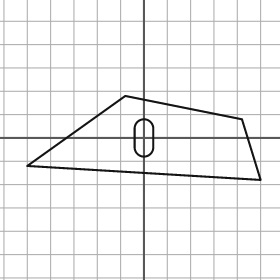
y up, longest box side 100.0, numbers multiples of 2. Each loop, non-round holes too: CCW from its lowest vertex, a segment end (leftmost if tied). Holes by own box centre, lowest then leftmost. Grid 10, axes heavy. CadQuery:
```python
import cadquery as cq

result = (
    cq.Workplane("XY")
    .moveTo(50.0, -18.0)
    .lineTo(42.0, 8.0)
    .lineTo(-8.0, 18.0)
    .lineTo(-50.0, -12.0)
    .close()
    .moveTo(-4.0, -4.0)
    .threePointArc((0.0, -8.0), (4.0, -4.0))
    .lineTo(4.0, 4.0)
    .threePointArc((0.0, 8.0), (-4.0, 4.0))
    .close()
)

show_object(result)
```